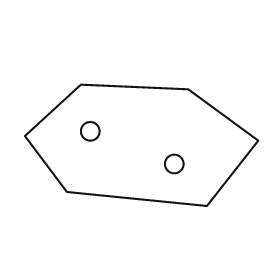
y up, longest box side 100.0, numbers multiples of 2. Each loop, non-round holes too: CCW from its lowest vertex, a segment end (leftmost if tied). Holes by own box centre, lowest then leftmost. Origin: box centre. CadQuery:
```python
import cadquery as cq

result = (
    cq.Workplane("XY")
    .moveTo(28.0, -26.0)
    .lineTo(50.0, 2.0)
    .lineTo(20.0, 24.0)
    .lineTo(-26.0, 26.0)
    .lineTo(-50.0, 4.0)
    .lineTo(-32.0, -20.0)
    .close()
    .moveTo(14.0, -8.0)
    .circle(4.0)
    .moveTo(-22.0, 6.0)
    .circle(4.0)
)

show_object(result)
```